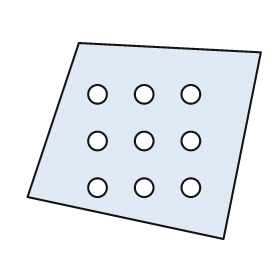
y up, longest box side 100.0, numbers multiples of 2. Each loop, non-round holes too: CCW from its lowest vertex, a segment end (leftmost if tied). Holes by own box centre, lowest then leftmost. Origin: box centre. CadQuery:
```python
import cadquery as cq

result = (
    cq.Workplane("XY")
    .moveTo(34.0, -42.0)
    .lineTo(50.0, 38.0)
    .lineTo(-28.0, 42.0)
    .lineTo(-50.0, -24.0)
    .close()
    .moveTo(-20.0, -20.0)
    .circle(4.0)
    .moveTo(0.0, -20.0)
    .circle(4.0)
    .moveTo(20.0, -20.0)
    .circle(4.0)
    .moveTo(-20.0, 0.0)
    .circle(4.0)
    .moveTo(0.0, 0.0)
    .circle(4.0)
    .moveTo(20.0, 0.0)
    .circle(4.0)
    .moveTo(-20.0, 20.0)
    .circle(4.0)
    .moveTo(0.0, 20.0)
    .circle(4.0)
    .moveTo(20.0, 20.0)
    .circle(4.0)
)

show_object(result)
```